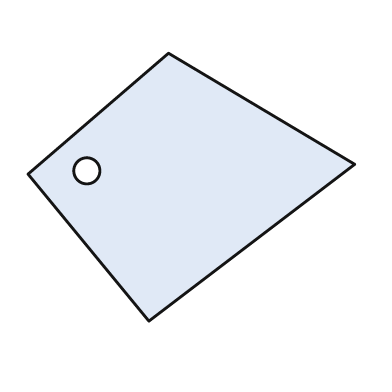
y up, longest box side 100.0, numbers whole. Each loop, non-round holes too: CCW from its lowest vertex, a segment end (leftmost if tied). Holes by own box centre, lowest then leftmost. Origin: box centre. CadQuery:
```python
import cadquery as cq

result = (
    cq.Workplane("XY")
    .moveTo(-13.0, -41.0)
    .lineTo(50.0, 7.0)
    .lineTo(-7.0, 41.0)
    .lineTo(-50.0, 4.0)
    .close()
    .moveTo(-32.0, 5.0)
    .circle(4.0)
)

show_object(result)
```